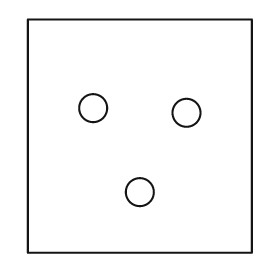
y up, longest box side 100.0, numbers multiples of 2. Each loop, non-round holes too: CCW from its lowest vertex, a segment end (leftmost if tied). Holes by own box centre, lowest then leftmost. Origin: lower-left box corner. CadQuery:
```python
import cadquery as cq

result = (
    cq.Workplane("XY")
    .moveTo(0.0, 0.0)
    .lineTo(96.0, 0.0)
    .lineTo(96.0, 100.0)
    .lineTo(0.0, 100.0)
    .close()
    .moveTo(48.0, 26.0)
    .circle(6.0)
    .moveTo(68.0, 60.0)
    .circle(6.0)
    .moveTo(28.0, 62.0)
    .circle(6.0)
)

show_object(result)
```